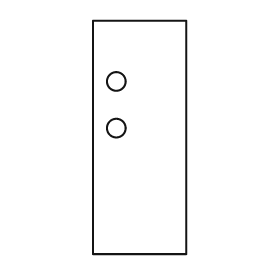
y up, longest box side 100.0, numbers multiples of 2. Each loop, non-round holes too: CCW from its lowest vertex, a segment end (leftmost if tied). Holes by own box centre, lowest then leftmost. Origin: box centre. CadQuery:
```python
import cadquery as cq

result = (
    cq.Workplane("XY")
    .moveTo(-20.0, -50.0)
    .lineTo(20.0, -50.0)
    .lineTo(20.0, 50.0)
    .lineTo(-20.0, 50.0)
    .close()
    .moveTo(-10.0, 4.0)
    .circle(4.0)
    .moveTo(-10.0, 24.0)
    .circle(4.0)
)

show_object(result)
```